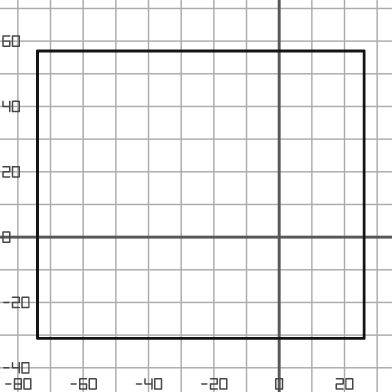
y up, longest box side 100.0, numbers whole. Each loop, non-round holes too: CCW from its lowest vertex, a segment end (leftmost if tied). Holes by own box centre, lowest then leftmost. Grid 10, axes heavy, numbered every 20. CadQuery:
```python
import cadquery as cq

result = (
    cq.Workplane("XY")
    .moveTo(-74.0, -31.0)
    .lineTo(26.0, -31.0)
    .lineTo(26.0, 57.0)
    .lineTo(-74.0, 57.0)
    .close()
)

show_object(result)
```